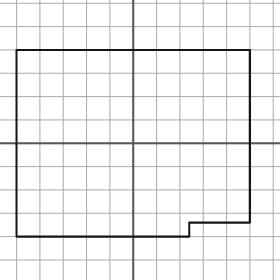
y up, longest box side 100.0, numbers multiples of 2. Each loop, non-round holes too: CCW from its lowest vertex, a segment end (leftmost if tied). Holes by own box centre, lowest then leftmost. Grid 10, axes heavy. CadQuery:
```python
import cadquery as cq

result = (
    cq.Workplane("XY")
    .moveTo(-50.0, -40.0)
    .lineTo(24.0, -40.0)
    .lineTo(24.0, -34.0)
    .lineTo(50.0, -34.0)
    .lineTo(50.0, 40.0)
    .lineTo(-50.0, 40.0)
    .close()
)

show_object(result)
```